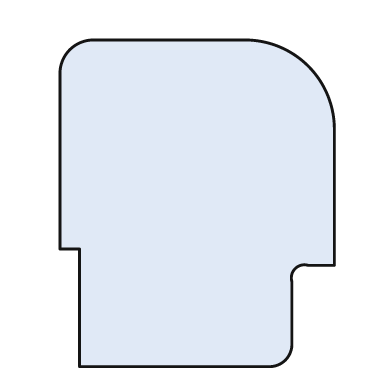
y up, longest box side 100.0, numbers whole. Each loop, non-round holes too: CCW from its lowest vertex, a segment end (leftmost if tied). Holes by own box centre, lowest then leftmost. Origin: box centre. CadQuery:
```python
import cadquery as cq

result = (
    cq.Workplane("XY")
    .moveTo(-36.0, -50.0)
    .lineTo(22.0, -50.0)
    .threePointArc((27.0, -48.0), (29.0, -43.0))
    .lineTo(29.0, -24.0)
    .threePointArc((30.0, -20.0), (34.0, -19.0))
    .lineTo(42.0, -19.0)
    .lineTo(42.0, 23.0)
    .threePointArc((34.0, 42.0), (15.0, 50.0))
    .lineTo(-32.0, 50.0)
    .threePointArc((-39.0, 47.0), (-42.0, 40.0))
    .lineTo(-42.0, -14.0)
    .lineTo(-36.0, -14.0)
    .close()
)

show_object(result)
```